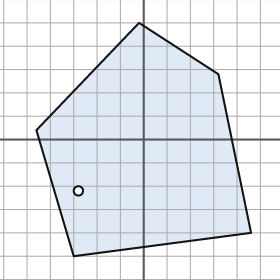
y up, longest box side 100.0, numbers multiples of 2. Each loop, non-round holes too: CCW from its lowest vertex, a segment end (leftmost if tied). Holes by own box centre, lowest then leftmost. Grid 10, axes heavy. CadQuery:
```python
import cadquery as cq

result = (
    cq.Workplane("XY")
    .moveTo(-30.0, -50.0)
    .lineTo(46.0, -40.0)
    .lineTo(32.0, 28.0)
    .lineTo(-2.0, 50.0)
    .lineTo(-46.0, 4.0)
    .close()
    .moveTo(-28.0, -22.0)
    .circle(2.0)
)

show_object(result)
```